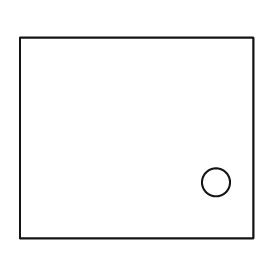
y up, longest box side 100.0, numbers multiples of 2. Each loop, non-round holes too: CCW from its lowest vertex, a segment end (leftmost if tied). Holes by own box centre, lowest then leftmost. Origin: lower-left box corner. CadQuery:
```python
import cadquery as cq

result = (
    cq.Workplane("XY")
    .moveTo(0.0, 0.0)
    .lineTo(100.0, 0.0)
    .lineTo(100.0, 86.0)
    .lineTo(0.0, 86.0)
    .close()
    .moveTo(84.0, 24.0)
    .circle(6.0)
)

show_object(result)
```